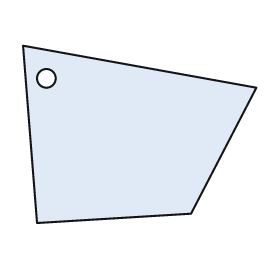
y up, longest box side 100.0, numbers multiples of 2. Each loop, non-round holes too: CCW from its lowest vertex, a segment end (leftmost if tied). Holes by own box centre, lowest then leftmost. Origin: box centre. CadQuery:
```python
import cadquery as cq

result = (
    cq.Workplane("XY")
    .moveTo(-44.0, -38.0)
    .lineTo(22.0, -34.0)
    .lineTo(50.0, 20.0)
    .lineTo(-50.0, 38.0)
    .close()
    .moveTo(-40.0, 24.0)
    .circle(4.0)
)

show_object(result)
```